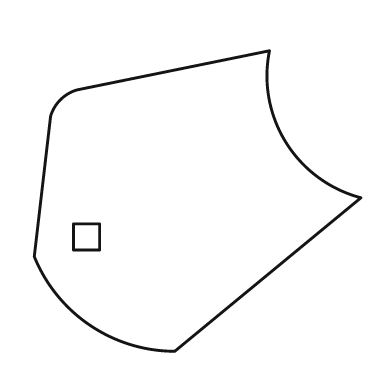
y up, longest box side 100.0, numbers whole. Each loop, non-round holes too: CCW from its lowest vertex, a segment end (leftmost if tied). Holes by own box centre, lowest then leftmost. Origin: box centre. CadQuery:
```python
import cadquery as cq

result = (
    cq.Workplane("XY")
    .moveTo(-7.0, -46.0)
    .lineTo(50.0, 1.0)
    .threePointArc((27.0, 18.0), (22.0, 46.0))
    .lineTo(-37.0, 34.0)
    .threePointArc((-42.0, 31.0), (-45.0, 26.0))
    .lineTo(-50.0, -17.0)
    .threePointArc((-33.0, -38.0), (-7.0, -46.0))
    .close()
    .moveTo(-38.0, -15.0)
    .lineTo(-30.0, -15.0)
    .lineTo(-30.0, -7.0)
    .lineTo(-38.0, -7.0)
    .close()
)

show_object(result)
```